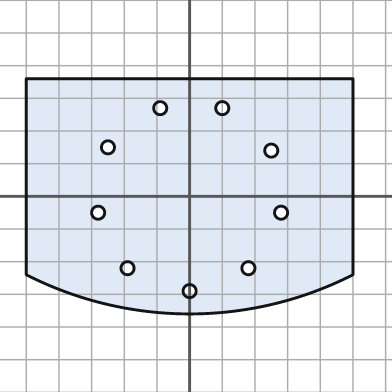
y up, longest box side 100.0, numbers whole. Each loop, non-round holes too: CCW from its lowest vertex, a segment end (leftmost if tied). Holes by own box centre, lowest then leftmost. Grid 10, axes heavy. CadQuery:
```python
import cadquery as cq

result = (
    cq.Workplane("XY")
    .moveTo(-50.0, -24.0)
    .threePointArc((0.0, -36.0), (50.0, -24.0))
    .lineTo(50.0, 36.0)
    .lineTo(-50.0, 36.0)
    .close()
    .moveTo(0.0, -29.0)
    .circle(2.0)
    .moveTo(-19.0, -22.0)
    .circle(2.0)
    .moveTo(18.0, -22.0)
    .circle(2.0)
    .moveTo(-28.0, -5.0)
    .circle(2.0)
    .moveTo(28.0, -5.0)
    .circle(2.0)
    .moveTo(25.0, 14.0)
    .circle(2.0)
    .moveTo(-25.0, 15.0)
    .circle(2.0)
    .moveTo(-9.0, 27.0)
    .circle(2.0)
    .moveTo(10.0, 27.0)
    .circle(2.0)
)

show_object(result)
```